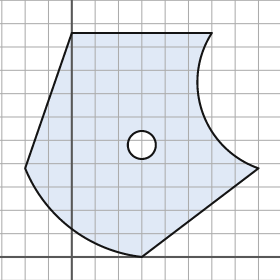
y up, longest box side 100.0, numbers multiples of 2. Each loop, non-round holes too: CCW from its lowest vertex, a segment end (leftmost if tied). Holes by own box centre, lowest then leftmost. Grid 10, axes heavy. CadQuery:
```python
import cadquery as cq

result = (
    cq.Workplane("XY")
    .moveTo(30.0, 0.0)
    .lineTo(80.0, 38.0)
    .threePointArc((56.0, 62.0), (60.0, 96.0))
    .lineTo(0.0, 96.0)
    .lineTo(-20.0, 38.0)
    .threePointArc((0.0, 12.0), (30.0, 0.0))
    .close()
    .moveTo(30.0, 48.0)
    .circle(6.0)
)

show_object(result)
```